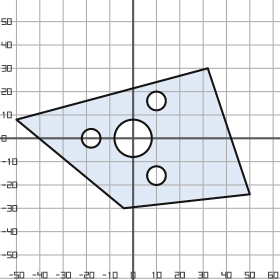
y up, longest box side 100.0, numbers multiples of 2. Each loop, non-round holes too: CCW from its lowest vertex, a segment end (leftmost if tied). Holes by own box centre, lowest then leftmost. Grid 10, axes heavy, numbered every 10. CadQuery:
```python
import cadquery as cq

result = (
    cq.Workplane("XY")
    .moveTo(-4.0, -30.0)
    .lineTo(50.0, -24.0)
    .lineTo(32.0, 30.0)
    .lineTo(-50.0, 8.0)
    .close()
    .moveTo(10.0, -16.0)
    .circle(4.0)
    .moveTo(-18.0, 0.0)
    .circle(4.0)
    .moveTo(0.0, 0.0)
    .circle(8.0)
    .moveTo(10.0, 16.0)
    .circle(4.0)
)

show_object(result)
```